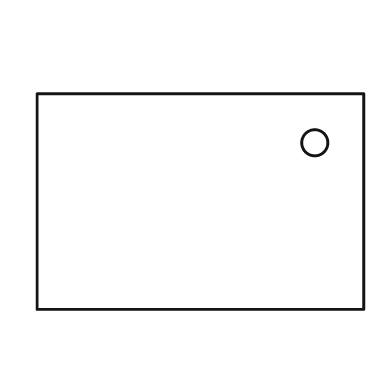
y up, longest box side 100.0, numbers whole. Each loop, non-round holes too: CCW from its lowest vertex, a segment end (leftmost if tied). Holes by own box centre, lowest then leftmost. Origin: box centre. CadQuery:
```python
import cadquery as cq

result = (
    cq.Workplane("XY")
    .moveTo(-50.0, -33.0)
    .lineTo(50.0, -33.0)
    .lineTo(50.0, 33.0)
    .lineTo(-50.0, 33.0)
    .close()
    .moveTo(35.0, 18.0)
    .circle(4.0)
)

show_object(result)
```